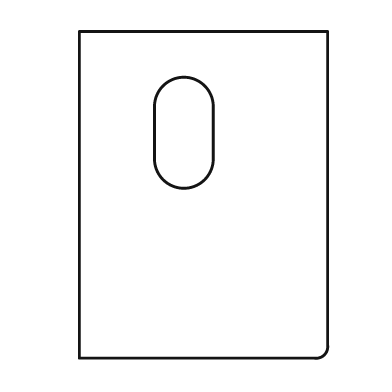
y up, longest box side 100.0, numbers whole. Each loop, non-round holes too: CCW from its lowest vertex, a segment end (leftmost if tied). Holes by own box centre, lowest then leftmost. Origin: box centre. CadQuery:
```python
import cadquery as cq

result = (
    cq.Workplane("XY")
    .moveTo(-38.0, -50.0)
    .lineTo(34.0, -50.0)
    .threePointArc((37.0, -49.0), (38.0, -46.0))
    .lineTo(38.0, 50.0)
    .lineTo(-38.0, 50.0)
    .close()
    .moveTo(-15.0, 11.0)
    .threePointArc((-6.0, 2.0), (3.0, 11.0))
    .lineTo(3.0, 27.0)
    .threePointArc((-6.0, 36.0), (-15.0, 27.0))
    .close()
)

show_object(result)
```